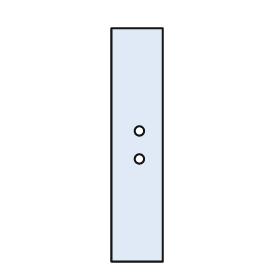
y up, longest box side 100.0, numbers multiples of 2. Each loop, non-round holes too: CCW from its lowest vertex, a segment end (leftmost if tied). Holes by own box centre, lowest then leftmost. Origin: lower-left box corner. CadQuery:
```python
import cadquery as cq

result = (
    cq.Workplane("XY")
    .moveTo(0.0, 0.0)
    .lineTo(22.0, 0.0)
    .lineTo(22.0, 100.0)
    .lineTo(0.0, 100.0)
    .close()
    .moveTo(12.0, 44.0)
    .circle(2.0)
    .moveTo(12.0, 56.0)
    .circle(2.0)
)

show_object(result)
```